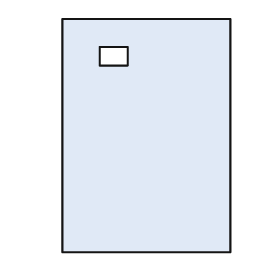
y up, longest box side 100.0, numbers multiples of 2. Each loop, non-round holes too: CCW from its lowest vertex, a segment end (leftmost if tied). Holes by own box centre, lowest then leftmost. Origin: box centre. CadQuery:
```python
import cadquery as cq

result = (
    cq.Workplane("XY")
    .moveTo(-36.0, -50.0)
    .lineTo(36.0, -50.0)
    .lineTo(36.0, 50.0)
    .lineTo(-36.0, 50.0)
    .close()
    .moveTo(-20.0, 30.0)
    .lineTo(-8.0, 30.0)
    .lineTo(-8.0, 38.0)
    .lineTo(-20.0, 38.0)
    .close()
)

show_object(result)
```